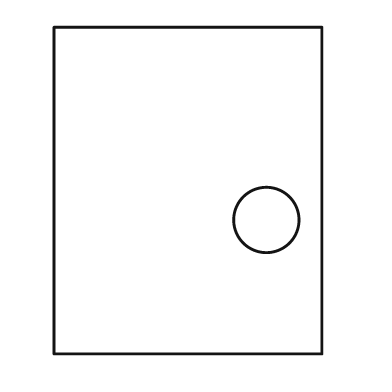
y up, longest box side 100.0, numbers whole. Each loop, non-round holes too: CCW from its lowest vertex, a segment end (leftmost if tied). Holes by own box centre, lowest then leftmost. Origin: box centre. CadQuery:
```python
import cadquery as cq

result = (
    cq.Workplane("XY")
    .moveTo(-41.0, -50.0)
    .lineTo(41.0, -50.0)
    .lineTo(41.0, 50.0)
    .lineTo(-41.0, 50.0)
    .close()
    .moveTo(24.0, -9.0)
    .circle(10.0)
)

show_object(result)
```